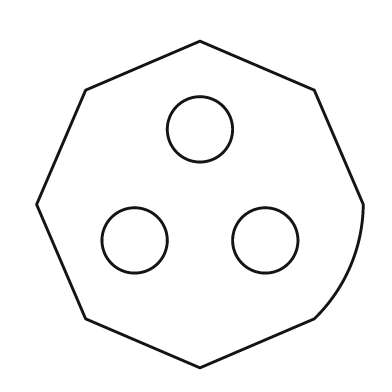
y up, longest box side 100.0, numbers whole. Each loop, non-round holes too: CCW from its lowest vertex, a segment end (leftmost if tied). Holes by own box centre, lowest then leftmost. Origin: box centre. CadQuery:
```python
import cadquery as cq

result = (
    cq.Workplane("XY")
    .moveTo(0.0, -50.0)
    .lineTo(35.0, -35.0)
    .threePointArc((46.0, -19.0), (50.0, 0.0))
    .lineTo(35.0, 35.0)
    .lineTo(0.0, 50.0)
    .lineTo(-35.0, 35.0)
    .lineTo(-50.0, 0.0)
    .lineTo(-35.0, -35.0)
    .close()
    .moveTo(-20.0, -11.0)
    .circle(10.0)
    .moveTo(20.0, -11.0)
    .circle(10.0)
    .moveTo(0.0, 23.0)
    .circle(10.0)
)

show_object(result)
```